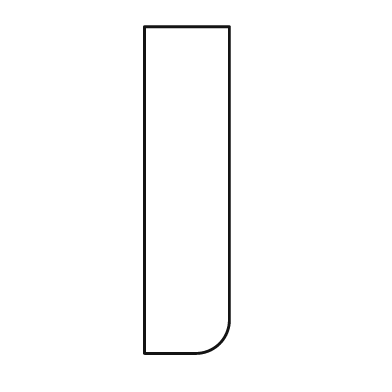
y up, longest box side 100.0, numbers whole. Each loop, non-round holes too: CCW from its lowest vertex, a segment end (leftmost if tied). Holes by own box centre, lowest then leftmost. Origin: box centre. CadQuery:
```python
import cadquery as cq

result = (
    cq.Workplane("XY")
    .moveTo(-13.0, -50.0)
    .lineTo(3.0, -50.0)
    .threePointArc((10.0, -47.0), (13.0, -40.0))
    .lineTo(13.0, 50.0)
    .lineTo(-13.0, 50.0)
    .close()
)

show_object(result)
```